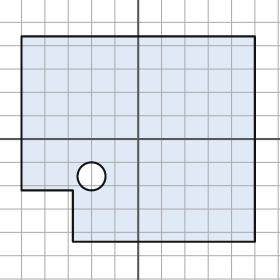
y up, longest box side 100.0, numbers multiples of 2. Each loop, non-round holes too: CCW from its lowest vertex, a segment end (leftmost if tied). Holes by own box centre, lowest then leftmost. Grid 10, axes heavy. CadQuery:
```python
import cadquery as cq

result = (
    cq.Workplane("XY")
    .moveTo(-28.0, -44.0)
    .lineTo(50.0, -44.0)
    .lineTo(50.0, 44.0)
    .lineTo(-50.0, 44.0)
    .lineTo(-50.0, -22.0)
    .lineTo(-28.0, -22.0)
    .close()
    .moveTo(-20.0, -16.0)
    .circle(6.0)
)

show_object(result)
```